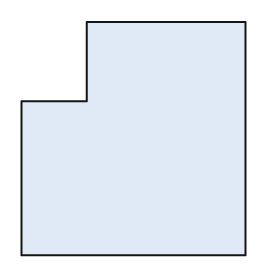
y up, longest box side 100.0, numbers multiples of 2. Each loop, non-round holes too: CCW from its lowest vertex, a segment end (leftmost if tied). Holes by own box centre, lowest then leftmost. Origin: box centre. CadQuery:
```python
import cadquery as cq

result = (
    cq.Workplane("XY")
    .moveTo(-48.0, -50.0)
    .lineTo(48.0, -50.0)
    .lineTo(48.0, 50.0)
    .lineTo(-20.0, 50.0)
    .lineTo(-20.0, 16.0)
    .lineTo(-48.0, 16.0)
    .close()
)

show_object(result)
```